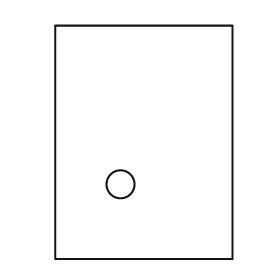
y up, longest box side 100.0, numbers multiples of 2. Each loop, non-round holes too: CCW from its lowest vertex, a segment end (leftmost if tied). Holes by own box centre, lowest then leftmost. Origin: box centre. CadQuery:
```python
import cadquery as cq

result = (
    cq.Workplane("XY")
    .moveTo(-38.0, -50.0)
    .lineTo(38.0, -50.0)
    .lineTo(38.0, 50.0)
    .lineTo(-38.0, 50.0)
    .close()
    .moveTo(-10.0, -18.0)
    .circle(6.0)
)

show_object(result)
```